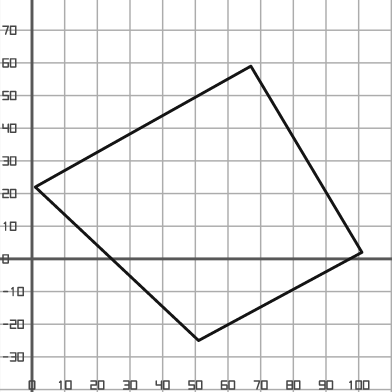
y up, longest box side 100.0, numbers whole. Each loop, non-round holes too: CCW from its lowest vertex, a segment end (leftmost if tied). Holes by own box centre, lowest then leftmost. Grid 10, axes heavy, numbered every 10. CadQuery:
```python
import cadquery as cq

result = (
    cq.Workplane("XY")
    .moveTo(51.0, -25.0)
    .lineTo(101.0, 2.0)
    .lineTo(67.0, 59.0)
    .lineTo(1.0, 22.0)
    .close()
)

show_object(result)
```